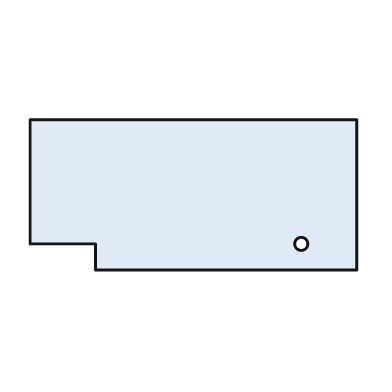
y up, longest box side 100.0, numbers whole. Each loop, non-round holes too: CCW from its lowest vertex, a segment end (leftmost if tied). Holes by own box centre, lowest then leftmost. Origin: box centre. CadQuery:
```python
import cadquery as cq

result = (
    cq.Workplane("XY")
    .moveTo(-30.0, -23.0)
    .lineTo(50.0, -23.0)
    .lineTo(50.0, 23.0)
    .lineTo(-50.0, 23.0)
    .lineTo(-50.0, -15.0)
    .lineTo(-30.0, -15.0)
    .close()
    .moveTo(33.0, -15.0)
    .circle(2.0)
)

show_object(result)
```